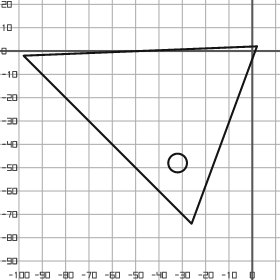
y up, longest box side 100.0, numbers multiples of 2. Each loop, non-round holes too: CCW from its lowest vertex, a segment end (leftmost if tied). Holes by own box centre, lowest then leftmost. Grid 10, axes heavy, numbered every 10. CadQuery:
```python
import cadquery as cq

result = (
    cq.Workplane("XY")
    .moveTo(-26.0, -74.0)
    .lineTo(2.0, 2.0)
    .lineTo(-98.0, -2.0)
    .close()
    .moveTo(-32.0, -48.0)
    .circle(4.0)
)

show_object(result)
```